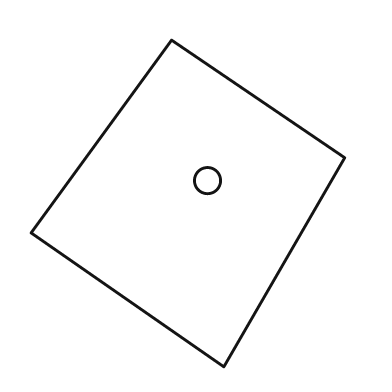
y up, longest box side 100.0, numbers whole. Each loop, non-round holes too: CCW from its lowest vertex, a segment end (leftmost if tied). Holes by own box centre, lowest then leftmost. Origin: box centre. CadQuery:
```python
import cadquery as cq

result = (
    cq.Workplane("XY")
    .moveTo(11.0, -50.0)
    .lineTo(48.0, 14.0)
    .lineTo(-5.0, 50.0)
    .lineTo(-48.0, -9.0)
    .close()
    .moveTo(6.0, 7.0)
    .circle(4.0)
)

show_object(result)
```